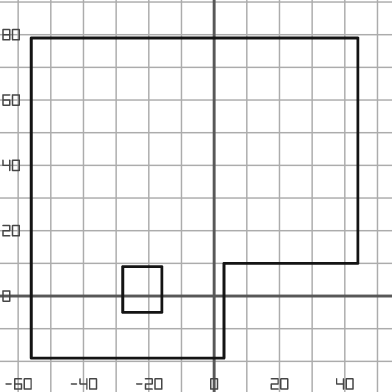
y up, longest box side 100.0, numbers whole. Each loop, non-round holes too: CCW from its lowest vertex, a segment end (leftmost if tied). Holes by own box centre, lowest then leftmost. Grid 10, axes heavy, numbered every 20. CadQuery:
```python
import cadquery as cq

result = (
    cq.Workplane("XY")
    .moveTo(-56.0, -19.0)
    .lineTo(3.0, -19.0)
    .lineTo(3.0, 10.0)
    .lineTo(44.0, 10.0)
    .lineTo(44.0, 79.0)
    .lineTo(-56.0, 79.0)
    .close()
    .moveTo(-28.0, -5.0)
    .lineTo(-16.0, -5.0)
    .lineTo(-16.0, 9.0)
    .lineTo(-28.0, 9.0)
    .close()
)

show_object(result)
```